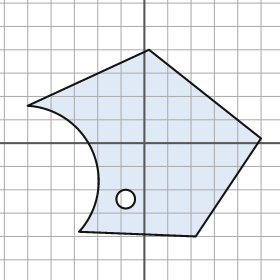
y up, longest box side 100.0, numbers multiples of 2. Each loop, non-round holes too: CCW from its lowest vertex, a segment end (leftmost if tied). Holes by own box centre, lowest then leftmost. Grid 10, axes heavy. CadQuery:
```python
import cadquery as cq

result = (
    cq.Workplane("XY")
    .moveTo(22.0, -40.0)
    .lineTo(50.0, 2.0)
    .lineTo(2.0, 40.0)
    .lineTo(-50.0, 16.0)
    .threePointArc((-22.0, -4.0), (-28.0, -38.0))
    .close()
    .moveTo(-8.0, -24.0)
    .circle(4.0)
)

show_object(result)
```